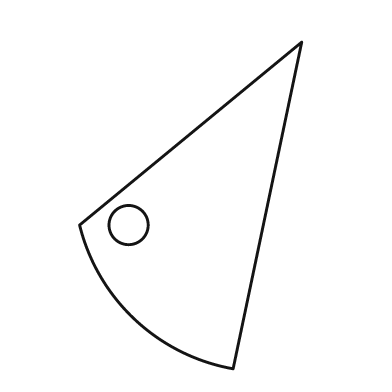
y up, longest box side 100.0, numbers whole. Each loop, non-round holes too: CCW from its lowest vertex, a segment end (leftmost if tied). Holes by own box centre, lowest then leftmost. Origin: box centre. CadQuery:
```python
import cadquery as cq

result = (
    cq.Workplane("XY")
    .moveTo(13.0, -50.0)
    .lineTo(34.0, 50.0)
    .lineTo(-34.0, -6.0)
    .threePointArc((-17.0, -35.0), (13.0, -50.0))
    .close()
    .moveTo(-19.0, -6.0)
    .circle(6.0)
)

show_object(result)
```